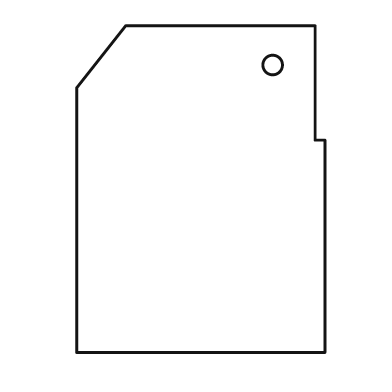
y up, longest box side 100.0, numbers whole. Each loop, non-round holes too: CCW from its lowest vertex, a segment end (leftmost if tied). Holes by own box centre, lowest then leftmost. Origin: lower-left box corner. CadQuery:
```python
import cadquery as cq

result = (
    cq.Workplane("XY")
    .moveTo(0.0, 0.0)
    .lineTo(76.0, 0.0)
    .lineTo(76.0, 65.0)
    .lineTo(73.0, 65.0)
    .lineTo(73.0, 100.0)
    .lineTo(15.0, 100.0)
    .lineTo(0.0, 81.0)
    .close()
    .moveTo(60.0, 88.0)
    .circle(3.0)
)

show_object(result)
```